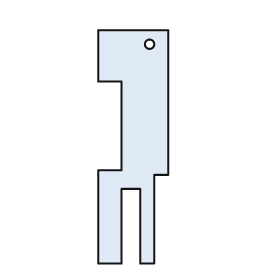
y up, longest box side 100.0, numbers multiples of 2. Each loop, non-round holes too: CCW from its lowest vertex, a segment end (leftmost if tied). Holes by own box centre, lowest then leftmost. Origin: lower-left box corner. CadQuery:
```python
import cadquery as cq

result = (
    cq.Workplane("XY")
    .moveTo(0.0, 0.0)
    .lineTo(10.0, 0.0)
    .lineTo(10.0, 32.0)
    .lineTo(18.0, 32.0)
    .lineTo(18.0, 0.0)
    .lineTo(24.0, 0.0)
    .lineTo(24.0, 38.0)
    .lineTo(30.0, 38.0)
    .lineTo(30.0, 100.0)
    .lineTo(0.0, 100.0)
    .lineTo(0.0, 78.0)
    .lineTo(10.0, 78.0)
    .lineTo(10.0, 40.0)
    .lineTo(0.0, 40.0)
    .close()
    .moveTo(22.0, 94.0)
    .circle(2.0)
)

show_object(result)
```